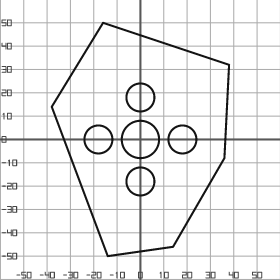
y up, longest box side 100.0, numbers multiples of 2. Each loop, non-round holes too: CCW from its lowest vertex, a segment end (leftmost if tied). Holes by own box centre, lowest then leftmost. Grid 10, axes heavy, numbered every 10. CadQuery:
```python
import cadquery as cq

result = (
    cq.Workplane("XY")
    .moveTo(-14.0, -50.0)
    .lineTo(14.0, -46.0)
    .lineTo(36.0, -8.0)
    .lineTo(38.0, 32.0)
    .lineTo(-16.0, 50.0)
    .lineTo(-38.0, 14.0)
    .close()
    .moveTo(0.0, -18.0)
    .circle(6.0)
    .moveTo(-18.0, 0.0)
    .circle(6.0)
    .moveTo(0.0, 0.0)
    .circle(8.0)
    .moveTo(18.0, 0.0)
    .circle(6.0)
    .moveTo(0.0, 18.0)
    .circle(6.0)
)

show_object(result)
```